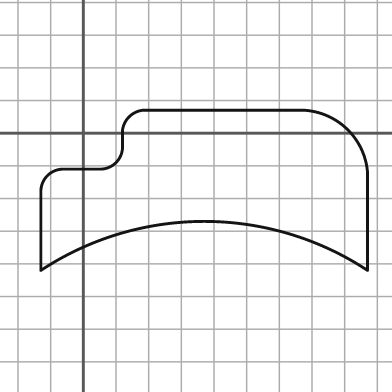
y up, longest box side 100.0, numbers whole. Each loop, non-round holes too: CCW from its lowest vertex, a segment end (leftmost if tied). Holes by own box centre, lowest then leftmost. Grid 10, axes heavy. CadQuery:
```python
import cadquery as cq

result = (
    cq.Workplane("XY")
    .moveTo(-13.0, -42.0)
    .threePointArc((37.0, -27.0), (87.0, -42.0))
    .lineTo(87.0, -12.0)
    .threePointArc((81.0, 1.0), (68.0, 7.0))
    .lineTo(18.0, 7.0)
    .threePointArc((14.0, 5.0), (12.0, 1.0))
    .lineTo(12.0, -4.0)
    .threePointArc((10.0, -9.0), (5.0, -11.0))
    .lineTo(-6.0, -11.0)
    .threePointArc((-11.0, -13.0), (-13.0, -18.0))
    .close()
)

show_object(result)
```